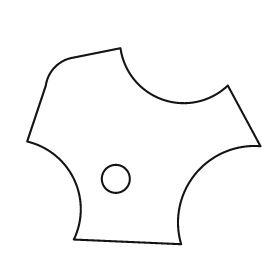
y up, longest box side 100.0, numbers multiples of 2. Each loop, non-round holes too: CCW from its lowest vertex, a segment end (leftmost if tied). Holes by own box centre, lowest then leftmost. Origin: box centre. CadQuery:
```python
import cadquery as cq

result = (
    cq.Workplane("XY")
    .moveTo(16.0, -42.0)
    .threePointArc((22.0, -12.0), (50.0, 0.0))
    .lineTo(36.0, 26.0)
    .threePointArc((8.0, 20.0), (-10.0, 42.0))
    .lineTo(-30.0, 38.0)
    .threePointArc((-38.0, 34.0), (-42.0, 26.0))
    .lineTo(-50.0, 2.0)
    .threePointArc((-30.0, -14.0), (-30.0, -40.0))
    .close()
    .moveTo(-12.0, -14.0)
    .circle(6.0)
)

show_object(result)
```